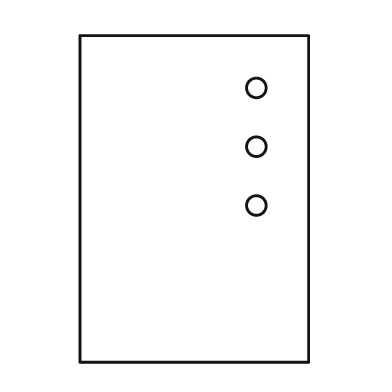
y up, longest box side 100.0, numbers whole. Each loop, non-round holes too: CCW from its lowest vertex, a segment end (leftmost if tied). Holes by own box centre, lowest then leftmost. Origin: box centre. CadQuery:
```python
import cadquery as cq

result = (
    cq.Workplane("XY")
    .moveTo(-35.0, -50.0)
    .lineTo(35.0, -50.0)
    .lineTo(35.0, 50.0)
    .lineTo(-35.0, 50.0)
    .close()
    .moveTo(19.0, -2.0)
    .circle(3.0)
    .moveTo(19.0, 16.0)
    .circle(3.0)
    .moveTo(19.0, 34.0)
    .circle(3.0)
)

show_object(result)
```